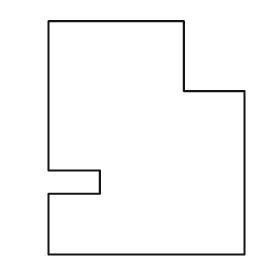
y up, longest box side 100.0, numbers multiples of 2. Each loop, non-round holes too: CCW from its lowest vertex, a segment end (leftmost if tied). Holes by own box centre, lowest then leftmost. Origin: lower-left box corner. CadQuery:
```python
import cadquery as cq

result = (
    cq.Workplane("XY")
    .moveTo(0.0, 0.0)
    .lineTo(84.0, 0.0)
    .lineTo(84.0, 70.0)
    .lineTo(58.0, 70.0)
    .lineTo(58.0, 100.0)
    .lineTo(0.0, 100.0)
    .lineTo(0.0, 36.0)
    .lineTo(22.0, 36.0)
    .lineTo(22.0, 26.0)
    .lineTo(0.0, 26.0)
    .close()
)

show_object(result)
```